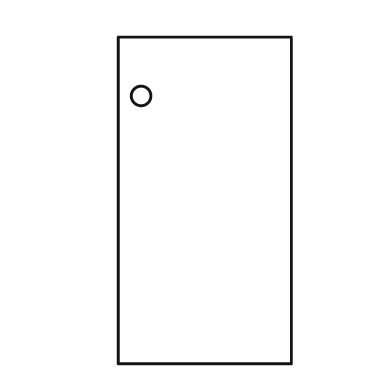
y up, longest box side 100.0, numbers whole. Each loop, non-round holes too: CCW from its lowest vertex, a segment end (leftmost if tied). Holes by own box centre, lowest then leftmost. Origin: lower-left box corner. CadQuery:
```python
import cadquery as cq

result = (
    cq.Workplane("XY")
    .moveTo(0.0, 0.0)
    .lineTo(53.0, 0.0)
    .lineTo(53.0, 100.0)
    .lineTo(0.0, 100.0)
    .close()
    .moveTo(7.0, 82.0)
    .circle(3.0)
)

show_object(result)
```